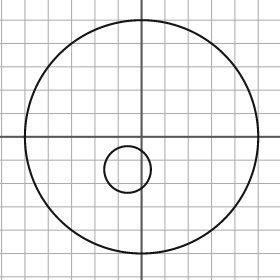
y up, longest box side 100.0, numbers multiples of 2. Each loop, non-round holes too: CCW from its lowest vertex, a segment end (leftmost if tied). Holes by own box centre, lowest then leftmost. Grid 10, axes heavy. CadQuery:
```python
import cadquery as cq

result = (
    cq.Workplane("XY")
    .moveTo(0.0, 0.0)
    .circle(50.0)
    .moveTo(-6.0, -14.0)
    .circle(10.0)
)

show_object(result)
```